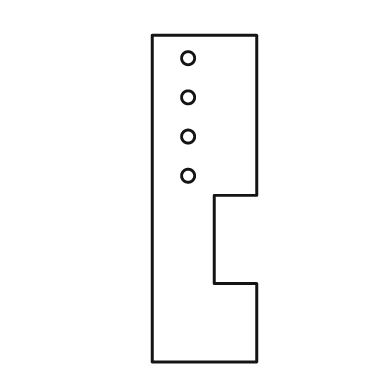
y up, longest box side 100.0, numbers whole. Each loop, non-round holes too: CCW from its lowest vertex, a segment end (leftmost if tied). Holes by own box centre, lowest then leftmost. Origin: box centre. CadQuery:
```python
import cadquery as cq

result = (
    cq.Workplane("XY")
    .moveTo(-16.0, -50.0)
    .lineTo(16.0, -50.0)
    .lineTo(16.0, -26.0)
    .lineTo(3.0, -26.0)
    .lineTo(3.0, 1.0)
    .lineTo(16.0, 1.0)
    .lineTo(16.0, 50.0)
    .lineTo(-16.0, 50.0)
    .close()
    .moveTo(-5.0, 7.0)
    .circle(2.0)
    .moveTo(-5.0, 19.0)
    .circle(2.0)
    .moveTo(-5.0, 31.0)
    .circle(2.0)
    .moveTo(-5.0, 43.0)
    .circle(2.0)
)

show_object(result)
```